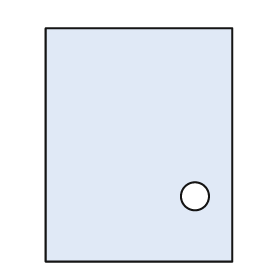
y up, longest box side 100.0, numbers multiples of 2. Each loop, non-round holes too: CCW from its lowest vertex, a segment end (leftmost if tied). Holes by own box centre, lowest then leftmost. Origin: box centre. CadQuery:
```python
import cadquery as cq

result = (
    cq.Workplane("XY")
    .moveTo(-40.0, -50.0)
    .lineTo(40.0, -50.0)
    .lineTo(40.0, 50.0)
    .lineTo(-40.0, 50.0)
    .close()
    .moveTo(24.0, -22.0)
    .circle(6.0)
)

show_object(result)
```